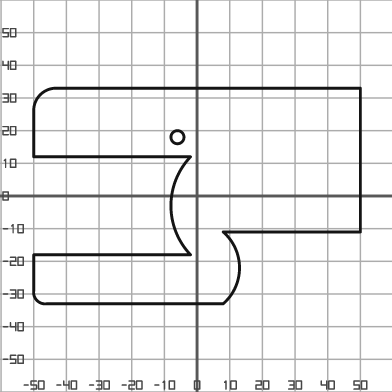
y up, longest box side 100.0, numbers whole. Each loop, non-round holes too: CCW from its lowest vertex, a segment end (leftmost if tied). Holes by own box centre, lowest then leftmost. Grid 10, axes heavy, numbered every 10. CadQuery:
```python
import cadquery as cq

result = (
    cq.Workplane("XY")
    .moveTo(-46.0, -33.0)
    .lineTo(8.0, -33.0)
    .threePointArc((13.0, -22.0), (8.0, -11.0))
    .lineTo(50.0, -11.0)
    .lineTo(50.0, 33.0)
    .lineTo(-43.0, 33.0)
    .threePointArc((-48.0, 31.0), (-50.0, 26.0))
    .lineTo(-50.0, 12.0)
    .lineTo(-2.0, 12.0)
    .threePointArc((-8.0, -3.0), (-2.0, -18.0))
    .lineTo(-50.0, -18.0)
    .lineTo(-50.0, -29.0)
    .threePointArc((-49.0, -32.0), (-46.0, -33.0))
    .close()
    .moveTo(-6.0, 18.0)
    .circle(2.0)
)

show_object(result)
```